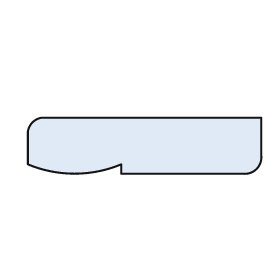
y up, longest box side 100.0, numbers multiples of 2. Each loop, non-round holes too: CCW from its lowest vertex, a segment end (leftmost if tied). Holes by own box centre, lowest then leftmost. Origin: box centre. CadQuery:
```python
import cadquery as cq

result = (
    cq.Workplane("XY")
    .moveTo(-10.0, -12.0)
    .lineTo(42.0, -12.0)
    .threePointArc((48.0, -10.0), (50.0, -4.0))
    .lineTo(50.0, 12.0)
    .lineTo(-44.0, 12.0)
    .threePointArc((-48.0, 10.0), (-50.0, 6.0))
    .lineTo(-50.0, -8.0)
    .threePointArc((-30.0, -12.0), (-10.0, -8.0))
    .close()
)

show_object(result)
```